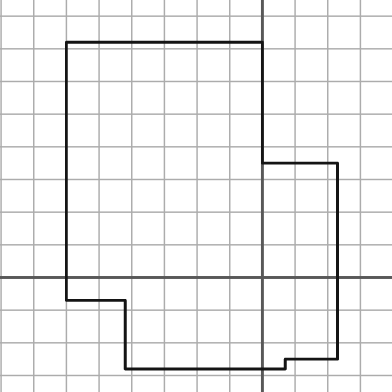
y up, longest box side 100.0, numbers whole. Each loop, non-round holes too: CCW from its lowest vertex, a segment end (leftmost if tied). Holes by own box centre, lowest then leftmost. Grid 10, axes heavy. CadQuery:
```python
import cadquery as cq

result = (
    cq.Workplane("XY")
    .moveTo(-42.0, -28.0)
    .lineTo(7.0, -28.0)
    .lineTo(7.0, -25.0)
    .lineTo(23.0, -25.0)
    .lineTo(23.0, 35.0)
    .lineTo(0.0, 35.0)
    .lineTo(0.0, 72.0)
    .lineTo(-60.0, 72.0)
    .lineTo(-60.0, -7.0)
    .lineTo(-42.0, -7.0)
    .close()
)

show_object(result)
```